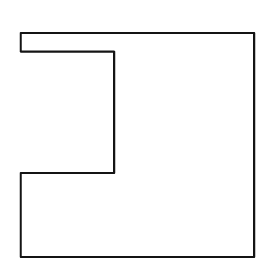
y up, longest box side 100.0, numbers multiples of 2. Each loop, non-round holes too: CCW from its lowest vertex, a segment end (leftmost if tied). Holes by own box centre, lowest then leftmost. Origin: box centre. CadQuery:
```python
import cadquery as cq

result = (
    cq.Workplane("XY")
    .moveTo(-50.0, -48.0)
    .lineTo(50.0, -48.0)
    .lineTo(50.0, 48.0)
    .lineTo(-50.0, 48.0)
    .lineTo(-50.0, 40.0)
    .lineTo(-10.0, 40.0)
    .lineTo(-10.0, -12.0)
    .lineTo(-50.0, -12.0)
    .close()
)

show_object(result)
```